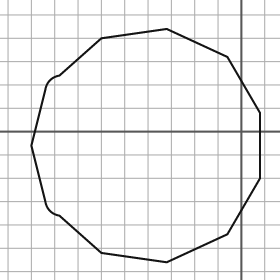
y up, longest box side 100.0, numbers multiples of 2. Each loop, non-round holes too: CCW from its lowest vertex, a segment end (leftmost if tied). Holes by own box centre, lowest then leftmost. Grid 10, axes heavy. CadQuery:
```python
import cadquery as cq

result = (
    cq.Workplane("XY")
    .moveTo(-32.0, -56.0)
    .lineTo(-6.0, -44.0)
    .lineTo(8.0, -20.0)
    .lineTo(8.0, 8.0)
    .lineTo(-6.0, 32.0)
    .lineTo(-32.0, 44.0)
    .lineTo(-60.0, 40.0)
    .lineTo(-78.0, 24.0)
    .threePointArc((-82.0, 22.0), (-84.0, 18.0))
    .lineTo(-90.0, -6.0)
    .lineTo(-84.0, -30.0)
    .threePointArc((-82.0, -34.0), (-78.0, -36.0))
    .lineTo(-60.0, -52.0)
    .close()
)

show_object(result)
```